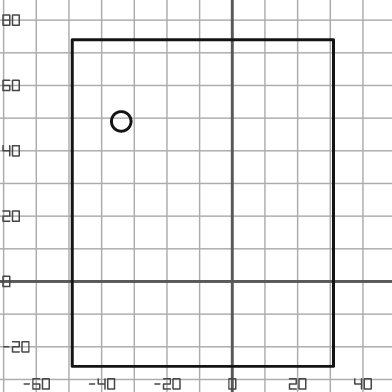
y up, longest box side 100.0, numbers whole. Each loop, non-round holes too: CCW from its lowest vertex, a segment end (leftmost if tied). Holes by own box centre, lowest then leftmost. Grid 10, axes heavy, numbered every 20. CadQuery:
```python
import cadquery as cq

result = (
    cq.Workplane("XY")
    .moveTo(-49.0, -26.0)
    .lineTo(31.0, -26.0)
    .lineTo(31.0, 74.0)
    .lineTo(-49.0, 74.0)
    .close()
    .moveTo(-34.0, 49.0)
    .circle(3.0)
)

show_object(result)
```